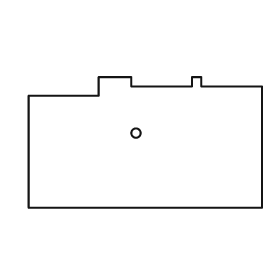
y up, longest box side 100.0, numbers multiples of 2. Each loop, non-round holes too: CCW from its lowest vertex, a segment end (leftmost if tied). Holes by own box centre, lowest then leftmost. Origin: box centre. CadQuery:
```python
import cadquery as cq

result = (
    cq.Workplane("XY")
    .moveTo(-50.0, -28.0)
    .lineTo(50.0, -28.0)
    .lineTo(50.0, 24.0)
    .lineTo(24.0, 24.0)
    .lineTo(24.0, 28.0)
    .lineTo(20.0, 28.0)
    .lineTo(20.0, 24.0)
    .lineTo(-6.0, 24.0)
    .lineTo(-6.0, 28.0)
    .lineTo(-20.0, 28.0)
    .lineTo(-20.0, 20.0)
    .lineTo(-50.0, 20.0)
    .close()
    .moveTo(-4.0, 4.0)
    .circle(2.0)
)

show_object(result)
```